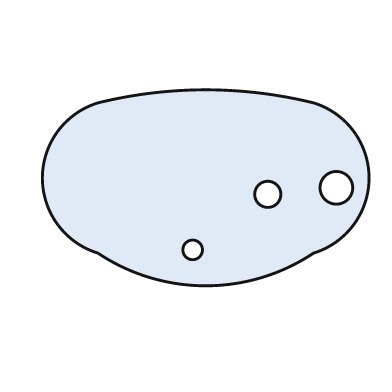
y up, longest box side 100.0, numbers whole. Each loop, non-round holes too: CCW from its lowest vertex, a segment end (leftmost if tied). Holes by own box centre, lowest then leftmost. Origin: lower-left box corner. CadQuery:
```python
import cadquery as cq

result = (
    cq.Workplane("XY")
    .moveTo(17.0, 10.0)
    .threePointArc((50.0, 0.0), (83.0, 10.0))
    .threePointArc((100.0, 33.0), (83.0, 56.0))
    .threePointArc((50.0, 60.0), (17.0, 56.0))
    .threePointArc((0.0, 33.0), (17.0, 10.0))
    .close()
    .moveTo(46.0, 11.0)
    .circle(3.0)
    .moveTo(69.0, 28.0)
    .circle(4.0)
    .moveTo(90.0, 30.0)
    .circle(5.0)
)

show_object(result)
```